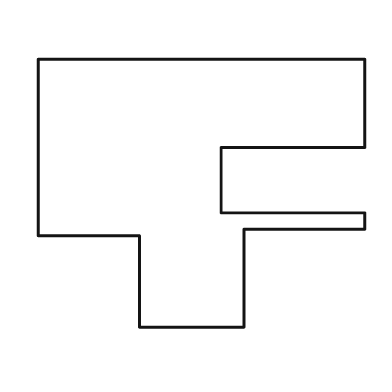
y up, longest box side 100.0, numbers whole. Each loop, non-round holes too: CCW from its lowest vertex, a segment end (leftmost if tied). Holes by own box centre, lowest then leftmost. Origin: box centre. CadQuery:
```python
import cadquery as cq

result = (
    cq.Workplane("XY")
    .moveTo(-19.0, -41.0)
    .lineTo(13.0, -41.0)
    .lineTo(13.0, -11.0)
    .lineTo(50.0, -11.0)
    .lineTo(50.0, -6.0)
    .lineTo(6.0, -6.0)
    .lineTo(6.0, 14.0)
    .lineTo(50.0, 14.0)
    .lineTo(50.0, 41.0)
    .lineTo(-50.0, 41.0)
    .lineTo(-50.0, -13.0)
    .lineTo(-19.0, -13.0)
    .close()
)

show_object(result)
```